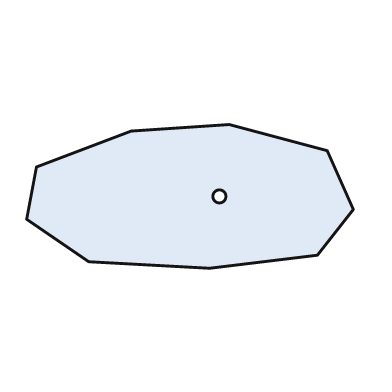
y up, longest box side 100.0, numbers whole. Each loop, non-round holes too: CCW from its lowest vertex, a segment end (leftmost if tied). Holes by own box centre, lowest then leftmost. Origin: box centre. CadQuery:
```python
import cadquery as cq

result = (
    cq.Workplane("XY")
    .moveTo(6.0, -22.0)
    .lineTo(39.0, -18.0)
    .lineTo(50.0, -4.0)
    .lineTo(42.0, 14.0)
    .lineTo(12.0, 22.0)
    .lineTo(-18.0, 20.0)
    .lineTo(-47.0, 9.0)
    .lineTo(-50.0, -7.0)
    .lineTo(-31.0, -20.0)
    .close()
    .moveTo(9.0, 0.0)
    .circle(2.0)
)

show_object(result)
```